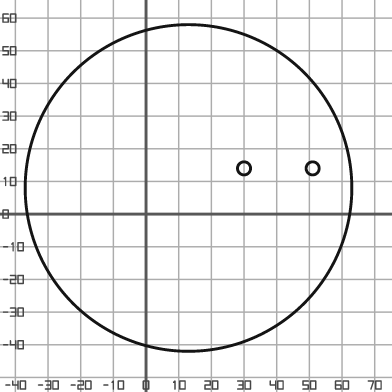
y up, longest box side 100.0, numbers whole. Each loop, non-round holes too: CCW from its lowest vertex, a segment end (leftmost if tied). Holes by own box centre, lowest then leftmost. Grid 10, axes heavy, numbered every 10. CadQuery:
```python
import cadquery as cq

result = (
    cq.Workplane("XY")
    .moveTo(13.0, 8.0)
    .circle(50.0)
    .moveTo(30.0, 14.0)
    .circle(2.0)
    .moveTo(51.0, 14.0)
    .circle(2.0)
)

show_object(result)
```